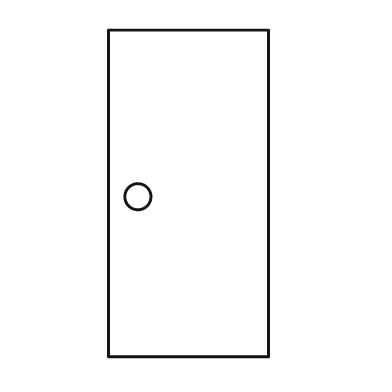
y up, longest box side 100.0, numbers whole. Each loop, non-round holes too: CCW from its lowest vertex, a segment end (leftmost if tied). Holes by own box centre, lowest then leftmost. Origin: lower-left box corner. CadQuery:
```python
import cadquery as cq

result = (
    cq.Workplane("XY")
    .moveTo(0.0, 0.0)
    .lineTo(49.0, 0.0)
    .lineTo(49.0, 100.0)
    .lineTo(0.0, 100.0)
    .close()
    .moveTo(9.0, 49.0)
    .circle(4.0)
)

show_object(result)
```